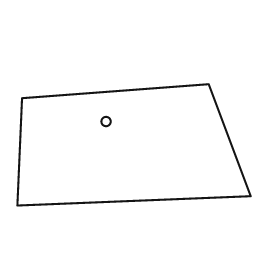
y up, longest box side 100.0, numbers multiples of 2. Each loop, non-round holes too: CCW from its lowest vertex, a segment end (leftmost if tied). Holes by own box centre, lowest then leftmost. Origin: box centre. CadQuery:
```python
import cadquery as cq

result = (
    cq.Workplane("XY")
    .moveTo(-50.0, -26.0)
    .lineTo(50.0, -22.0)
    .lineTo(32.0, 26.0)
    .lineTo(-48.0, 20.0)
    .close()
    .moveTo(-12.0, 10.0)
    .circle(2.0)
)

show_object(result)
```